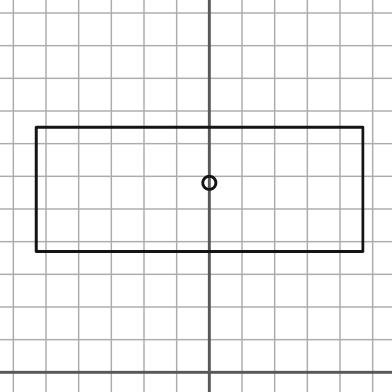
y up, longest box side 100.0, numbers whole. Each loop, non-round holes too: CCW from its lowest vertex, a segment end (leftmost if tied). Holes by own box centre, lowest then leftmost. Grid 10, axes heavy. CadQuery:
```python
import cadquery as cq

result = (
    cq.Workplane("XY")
    .moveTo(-53.0, 37.0)
    .lineTo(47.0, 37.0)
    .lineTo(47.0, 75.0)
    .lineTo(-53.0, 75.0)
    .close()
    .moveTo(0.0, 58.0)
    .circle(2.0)
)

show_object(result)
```